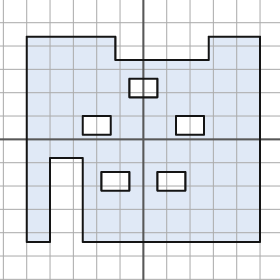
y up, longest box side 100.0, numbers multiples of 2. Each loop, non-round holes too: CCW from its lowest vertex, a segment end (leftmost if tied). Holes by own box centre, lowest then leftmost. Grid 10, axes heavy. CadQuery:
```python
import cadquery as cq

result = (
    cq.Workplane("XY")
    .moveTo(-50.0, -44.0)
    .lineTo(-40.0, -44.0)
    .lineTo(-40.0, -8.0)
    .lineTo(-26.0, -8.0)
    .lineTo(-26.0, -44.0)
    .lineTo(50.0, -44.0)
    .lineTo(50.0, 44.0)
    .lineTo(28.0, 44.0)
    .lineTo(28.0, 34.0)
    .lineTo(-12.0, 34.0)
    .lineTo(-12.0, 44.0)
    .lineTo(-50.0, 44.0)
    .close()
    .moveTo(-18.0, -22.0)
    .lineTo(-6.0, -22.0)
    .lineTo(-6.0, -14.0)
    .lineTo(-18.0, -14.0)
    .close()
    .moveTo(6.0, -22.0)
    .lineTo(18.0, -22.0)
    .lineTo(18.0, -14.0)
    .lineTo(6.0, -14.0)
    .close()
    .moveTo(-26.0, 2.0)
    .lineTo(-14.0, 2.0)
    .lineTo(-14.0, 10.0)
    .lineTo(-26.0, 10.0)
    .close()
    .moveTo(14.0, 2.0)
    .lineTo(26.0, 2.0)
    .lineTo(26.0, 10.0)
    .lineTo(14.0, 10.0)
    .close()
    .moveTo(-6.0, 18.0)
    .lineTo(6.0, 18.0)
    .lineTo(6.0, 26.0)
    .lineTo(-6.0, 26.0)
    .close()
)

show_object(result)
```